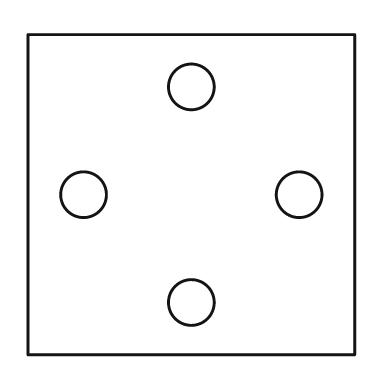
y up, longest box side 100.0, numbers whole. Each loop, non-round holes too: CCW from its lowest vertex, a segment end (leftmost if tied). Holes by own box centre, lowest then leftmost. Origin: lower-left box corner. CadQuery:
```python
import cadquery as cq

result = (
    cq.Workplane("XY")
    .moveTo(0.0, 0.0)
    .lineTo(100.0, 0.0)
    .lineTo(100.0, 98.0)
    .lineTo(0.0, 98.0)
    .close()
    .moveTo(50.0, 16.0)
    .circle(7.0)
    .moveTo(17.0, 49.0)
    .circle(7.0)
    .moveTo(83.0, 49.0)
    .circle(7.0)
    .moveTo(50.0, 82.0)
    .circle(7.0)
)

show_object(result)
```